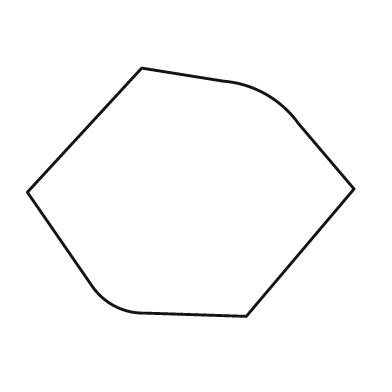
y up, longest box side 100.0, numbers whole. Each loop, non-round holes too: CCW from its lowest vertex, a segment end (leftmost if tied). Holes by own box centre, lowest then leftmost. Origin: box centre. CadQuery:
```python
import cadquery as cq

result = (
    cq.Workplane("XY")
    .moveTo(17.0, -38.0)
    .lineTo(50.0, 1.0)
    .lineTo(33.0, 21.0)
    .threePointArc((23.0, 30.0), (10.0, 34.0))
    .lineTo(-15.0, 38.0)
    .lineTo(-50.0, 0.0)
    .lineTo(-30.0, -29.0)
    .threePointArc((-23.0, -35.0), (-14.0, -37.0))
    .close()
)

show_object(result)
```